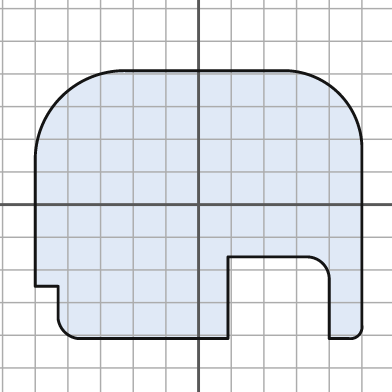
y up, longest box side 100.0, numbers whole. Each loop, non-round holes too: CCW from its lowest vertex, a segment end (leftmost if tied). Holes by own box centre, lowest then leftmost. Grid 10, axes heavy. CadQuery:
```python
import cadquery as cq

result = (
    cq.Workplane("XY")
    .moveTo(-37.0, -41.0)
    .lineTo(9.0, -41.0)
    .lineTo(9.0, -16.0)
    .lineTo(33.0, -16.0)
    .threePointArc((38.0, -18.0), (40.0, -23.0))
    .lineTo(40.0, -41.0)
    .lineTo(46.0, -41.0)
    .threePointArc((49.0, -40.0), (50.0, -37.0))
    .lineTo(50.0, 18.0)
    .threePointArc((43.0, 34.0), (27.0, 41.0))
    .lineTo(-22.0, 41.0)
    .threePointArc((-42.0, 33.0), (-50.0, 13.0))
    .lineTo(-50.0, -25.0)
    .lineTo(-43.0, -25.0)
    .lineTo(-43.0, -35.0)
    .threePointArc((-41.0, -39.0), (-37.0, -41.0))
    .close()
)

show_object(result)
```